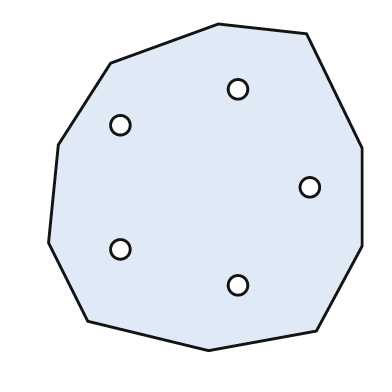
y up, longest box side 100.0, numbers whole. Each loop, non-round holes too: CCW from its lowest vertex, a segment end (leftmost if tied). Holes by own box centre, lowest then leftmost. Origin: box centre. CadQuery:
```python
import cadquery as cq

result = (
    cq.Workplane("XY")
    .moveTo(1.0, -50.0)
    .lineTo(34.0, -44.0)
    .lineTo(48.0, -18.0)
    .lineTo(48.0, 12.0)
    .lineTo(31.0, 47.0)
    .lineTo(4.0, 50.0)
    .lineTo(-29.0, 38.0)
    .lineTo(-45.0, 13.0)
    .lineTo(-48.0, -17.0)
    .lineTo(-36.0, -41.0)
    .close()
    .moveTo(10.0, -30.0)
    .circle(3.0)
    .moveTo(-26.0, -19.0)
    .circle(3.0)
    .moveTo(32.0, 0.0)
    .circle(3.0)
    .moveTo(-26.0, 19.0)
    .circle(3.0)
    .moveTo(10.0, 30.0)
    .circle(3.0)
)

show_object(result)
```